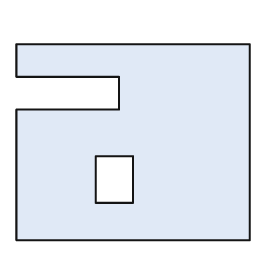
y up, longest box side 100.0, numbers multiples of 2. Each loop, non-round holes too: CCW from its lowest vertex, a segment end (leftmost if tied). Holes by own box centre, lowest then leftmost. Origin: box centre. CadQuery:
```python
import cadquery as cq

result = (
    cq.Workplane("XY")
    .moveTo(-50.0, -42.0)
    .lineTo(50.0, -42.0)
    .lineTo(50.0, 42.0)
    .lineTo(-50.0, 42.0)
    .lineTo(-50.0, 28.0)
    .lineTo(-6.0, 28.0)
    .lineTo(-6.0, 14.0)
    .lineTo(-50.0, 14.0)
    .close()
    .moveTo(-16.0, -26.0)
    .lineTo(0.0, -26.0)
    .lineTo(0.0, -6.0)
    .lineTo(-16.0, -6.0)
    .close()
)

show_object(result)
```